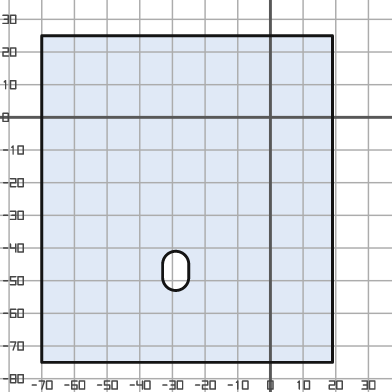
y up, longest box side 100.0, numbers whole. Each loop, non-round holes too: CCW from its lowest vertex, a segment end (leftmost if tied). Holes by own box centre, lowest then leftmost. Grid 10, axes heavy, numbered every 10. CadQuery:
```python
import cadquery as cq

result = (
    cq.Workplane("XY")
    .moveTo(-70.0, -75.0)
    .lineTo(19.0, -75.0)
    .lineTo(19.0, 25.0)
    .lineTo(-70.0, 25.0)
    .close()
    .moveTo(-33.0, -49.0)
    .threePointArc((-29.0, -53.0), (-25.0, -49.0))
    .lineTo(-25.0, -45.0)
    .threePointArc((-29.0, -41.0), (-33.0, -45.0))
    .close()
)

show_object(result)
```